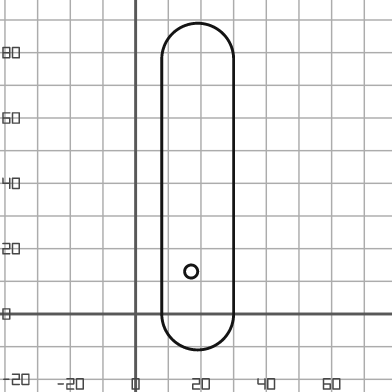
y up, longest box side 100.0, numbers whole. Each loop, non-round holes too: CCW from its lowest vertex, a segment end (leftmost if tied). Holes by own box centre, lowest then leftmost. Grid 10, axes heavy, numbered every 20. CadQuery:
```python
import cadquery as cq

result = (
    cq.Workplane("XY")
    .moveTo(8.0, 0.0)
    .threePointArc((19.0, -11.0), (30.0, 0.0))
    .lineTo(30.0, 78.0)
    .threePointArc((19.0, 89.0), (8.0, 78.0))
    .close()
    .moveTo(17.0, 13.0)
    .circle(2.0)
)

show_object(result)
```